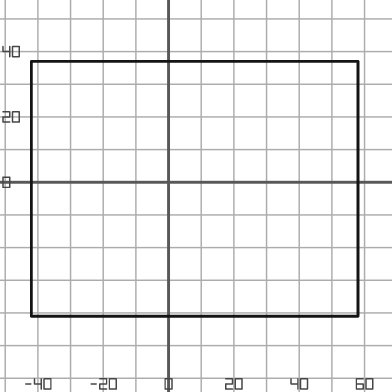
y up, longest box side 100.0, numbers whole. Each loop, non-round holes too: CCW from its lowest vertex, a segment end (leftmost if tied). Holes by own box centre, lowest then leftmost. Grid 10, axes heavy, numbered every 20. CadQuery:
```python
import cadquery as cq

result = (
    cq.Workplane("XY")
    .moveTo(-42.0, -41.0)
    .lineTo(58.0, -41.0)
    .lineTo(58.0, 37.0)
    .lineTo(-42.0, 37.0)
    .close()
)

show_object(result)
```